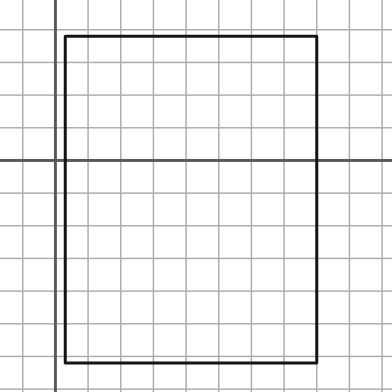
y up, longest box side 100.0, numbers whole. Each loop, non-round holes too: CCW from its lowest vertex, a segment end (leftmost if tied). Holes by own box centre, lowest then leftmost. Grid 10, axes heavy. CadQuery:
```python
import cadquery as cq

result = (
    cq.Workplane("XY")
    .moveTo(3.0, -62.0)
    .lineTo(80.0, -62.0)
    .lineTo(80.0, 38.0)
    .lineTo(3.0, 38.0)
    .close()
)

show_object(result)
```